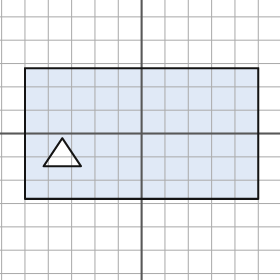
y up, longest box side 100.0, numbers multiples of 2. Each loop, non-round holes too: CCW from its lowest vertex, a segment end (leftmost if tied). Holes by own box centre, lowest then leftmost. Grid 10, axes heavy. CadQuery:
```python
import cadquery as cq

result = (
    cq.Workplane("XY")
    .moveTo(-50.0, -28.0)
    .lineTo(50.0, -28.0)
    .lineTo(50.0, 28.0)
    .lineTo(-50.0, 28.0)
    .close()
    .moveTo(-42.0, -14.0)
    .lineTo(-26.0, -14.0)
    .lineTo(-34.0, -2.0)
    .close()
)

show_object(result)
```